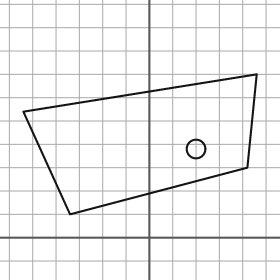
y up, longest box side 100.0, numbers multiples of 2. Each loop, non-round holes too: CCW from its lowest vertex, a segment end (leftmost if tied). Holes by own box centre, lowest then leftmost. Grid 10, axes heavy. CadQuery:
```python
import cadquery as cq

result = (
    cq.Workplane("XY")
    .moveTo(-34.0, 10.0)
    .lineTo(42.0, 30.0)
    .lineTo(46.0, 70.0)
    .lineTo(-54.0, 54.0)
    .close()
    .moveTo(20.0, 38.0)
    .circle(4.0)
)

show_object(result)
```